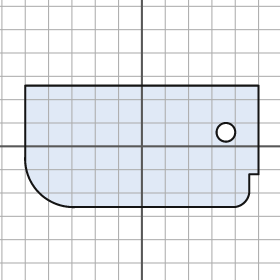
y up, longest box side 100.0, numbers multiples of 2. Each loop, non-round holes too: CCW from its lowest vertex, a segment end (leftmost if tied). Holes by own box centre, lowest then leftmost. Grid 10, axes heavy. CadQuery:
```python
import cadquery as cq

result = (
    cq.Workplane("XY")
    .moveTo(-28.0, -26.0)
    .lineTo(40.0, -26.0)
    .threePointArc((44.0, -24.0), (46.0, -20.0))
    .lineTo(46.0, -12.0)
    .lineTo(50.0, -12.0)
    .lineTo(50.0, 26.0)
    .lineTo(-50.0, 26.0)
    .lineTo(-50.0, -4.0)
    .threePointArc((-44.0, -20.0), (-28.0, -26.0))
    .close()
    .moveTo(36.0, 6.0)
    .circle(4.0)
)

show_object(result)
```